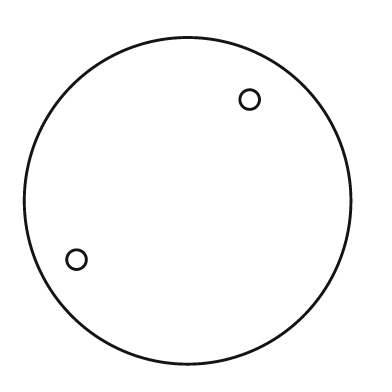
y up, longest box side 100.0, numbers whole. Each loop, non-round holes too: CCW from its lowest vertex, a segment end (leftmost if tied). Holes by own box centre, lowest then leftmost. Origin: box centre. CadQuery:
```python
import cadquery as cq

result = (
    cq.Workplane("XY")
    .moveTo(0.0, 0.0)
    .circle(50.0)
    .moveTo(-34.0, -18.0)
    .circle(3.0)
    .moveTo(19.0, 31.0)
    .circle(3.0)
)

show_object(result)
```